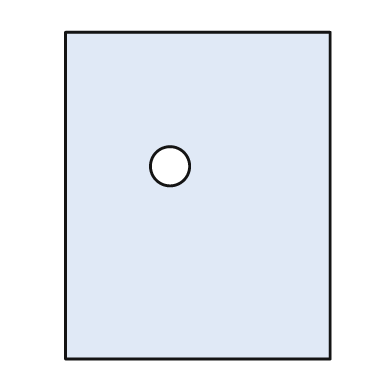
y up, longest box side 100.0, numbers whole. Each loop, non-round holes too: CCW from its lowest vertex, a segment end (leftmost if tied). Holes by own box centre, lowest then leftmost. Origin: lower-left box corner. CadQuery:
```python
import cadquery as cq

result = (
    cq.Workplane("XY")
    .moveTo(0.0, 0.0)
    .lineTo(81.0, 0.0)
    .lineTo(81.0, 100.0)
    .lineTo(0.0, 100.0)
    .close()
    .moveTo(32.0, 59.0)
    .circle(6.0)
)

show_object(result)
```